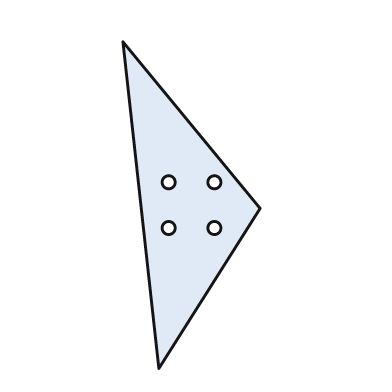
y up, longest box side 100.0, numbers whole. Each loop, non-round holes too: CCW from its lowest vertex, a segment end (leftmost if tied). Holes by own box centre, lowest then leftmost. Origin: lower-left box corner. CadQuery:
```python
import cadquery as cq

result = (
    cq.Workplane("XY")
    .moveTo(11.0, 0.0)
    .lineTo(42.0, 49.0)
    .lineTo(0.0, 100.0)
    .close()
    .moveTo(14.0, 43.0)
    .circle(2.0)
    .moveTo(28.0, 43.0)
    .circle(2.0)
    .moveTo(14.0, 57.0)
    .circle(2.0)
    .moveTo(28.0, 57.0)
    .circle(2.0)
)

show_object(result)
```